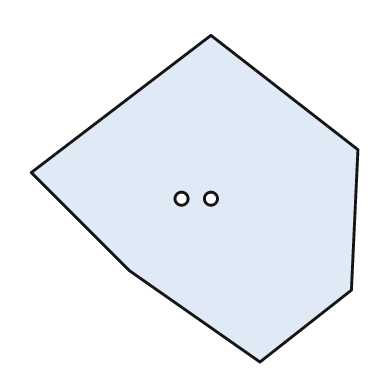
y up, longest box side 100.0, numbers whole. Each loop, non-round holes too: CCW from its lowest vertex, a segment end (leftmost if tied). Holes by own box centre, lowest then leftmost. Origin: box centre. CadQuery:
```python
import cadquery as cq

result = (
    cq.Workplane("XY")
    .moveTo(20.0, -50.0)
    .lineTo(48.0, -28.0)
    .lineTo(50.0, 15.0)
    .lineTo(5.0, 50.0)
    .lineTo(-50.0, 8.0)
    .lineTo(-20.0, -22.0)
    .close()
    .moveTo(-4.0, 0.0)
    .circle(2.0)
    .moveTo(5.0, 0.0)
    .circle(2.0)
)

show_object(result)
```